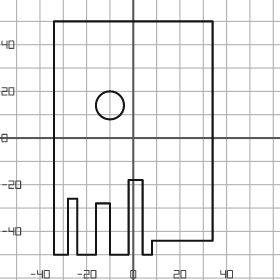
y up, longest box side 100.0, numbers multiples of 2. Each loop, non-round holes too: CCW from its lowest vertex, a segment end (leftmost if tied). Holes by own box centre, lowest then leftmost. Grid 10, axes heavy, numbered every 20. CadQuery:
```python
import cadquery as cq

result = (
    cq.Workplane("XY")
    .moveTo(-34.0, -50.0)
    .lineTo(-28.0, -50.0)
    .lineTo(-28.0, -26.0)
    .lineTo(-24.0, -26.0)
    .lineTo(-24.0, -50.0)
    .lineTo(-16.0, -50.0)
    .lineTo(-16.0, -28.0)
    .lineTo(-10.0, -28.0)
    .lineTo(-10.0, -50.0)
    .lineTo(-2.0, -50.0)
    .lineTo(-2.0, -18.0)
    .lineTo(4.0, -18.0)
    .lineTo(4.0, -50.0)
    .lineTo(8.0, -50.0)
    .lineTo(8.0, -44.0)
    .lineTo(34.0, -44.0)
    .lineTo(34.0, 50.0)
    .lineTo(-34.0, 50.0)
    .close()
    .moveTo(-10.0, 14.0)
    .circle(6.0)
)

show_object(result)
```